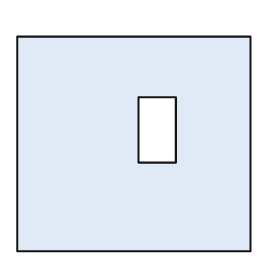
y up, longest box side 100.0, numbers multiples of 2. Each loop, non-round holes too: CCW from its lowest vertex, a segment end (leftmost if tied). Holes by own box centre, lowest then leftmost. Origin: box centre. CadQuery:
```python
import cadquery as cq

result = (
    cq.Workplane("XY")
    .moveTo(-50.0, -46.0)
    .lineTo(50.0, -46.0)
    .lineTo(50.0, 46.0)
    .lineTo(-50.0, 46.0)
    .close()
    .moveTo(2.0, -8.0)
    .lineTo(18.0, -8.0)
    .lineTo(18.0, 20.0)
    .lineTo(2.0, 20.0)
    .close()
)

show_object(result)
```